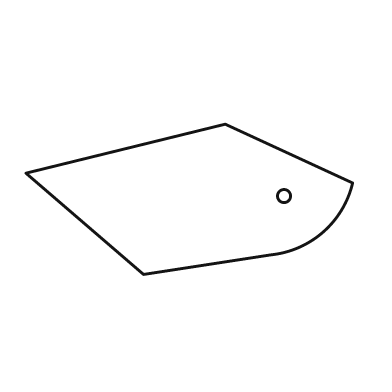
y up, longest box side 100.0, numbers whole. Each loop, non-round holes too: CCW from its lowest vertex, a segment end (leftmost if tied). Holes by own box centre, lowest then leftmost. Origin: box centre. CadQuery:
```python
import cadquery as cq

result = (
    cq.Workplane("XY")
    .moveTo(-14.0, -23.0)
    .lineTo(25.0, -17.0)
    .threePointArc((41.0, -10.0), (50.0, 5.0))
    .lineTo(11.0, 23.0)
    .lineTo(-50.0, 8.0)
    .close()
    .moveTo(29.0, 1.0)
    .circle(2.0)
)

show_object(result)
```